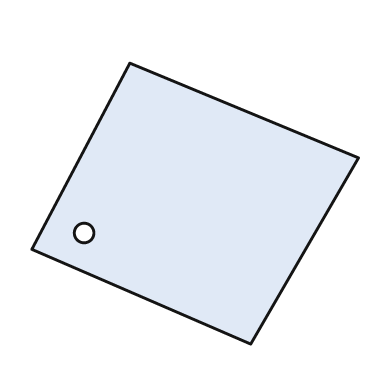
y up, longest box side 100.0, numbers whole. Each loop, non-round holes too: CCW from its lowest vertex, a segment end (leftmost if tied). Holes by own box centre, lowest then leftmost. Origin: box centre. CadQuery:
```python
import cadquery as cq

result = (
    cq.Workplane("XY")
    .moveTo(17.0, -43.0)
    .lineTo(50.0, 14.0)
    .lineTo(-20.0, 43.0)
    .lineTo(-50.0, -14.0)
    .close()
    .moveTo(-34.0, -9.0)
    .circle(3.0)
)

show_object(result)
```